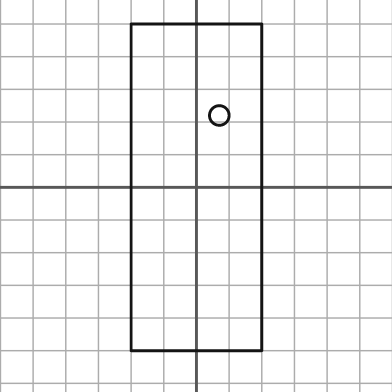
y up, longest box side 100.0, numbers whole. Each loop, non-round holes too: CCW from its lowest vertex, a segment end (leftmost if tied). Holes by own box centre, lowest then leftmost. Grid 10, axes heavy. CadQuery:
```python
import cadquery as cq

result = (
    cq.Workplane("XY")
    .moveTo(-20.0, -50.0)
    .lineTo(20.0, -50.0)
    .lineTo(20.0, 50.0)
    .lineTo(-20.0, 50.0)
    .close()
    .moveTo(7.0, 22.0)
    .circle(3.0)
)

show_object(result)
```